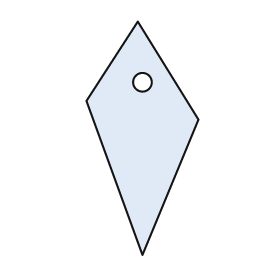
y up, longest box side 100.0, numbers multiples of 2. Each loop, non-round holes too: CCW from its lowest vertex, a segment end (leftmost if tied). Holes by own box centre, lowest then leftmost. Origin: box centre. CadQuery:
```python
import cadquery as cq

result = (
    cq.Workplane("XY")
    .moveTo(0.0, -50.0)
    .lineTo(24.0, 8.0)
    .lineTo(-2.0, 50.0)
    .lineTo(-24.0, 16.0)
    .close()
    .moveTo(0.0, 24.0)
    .circle(4.0)
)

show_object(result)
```